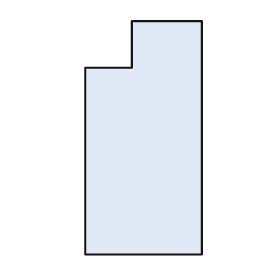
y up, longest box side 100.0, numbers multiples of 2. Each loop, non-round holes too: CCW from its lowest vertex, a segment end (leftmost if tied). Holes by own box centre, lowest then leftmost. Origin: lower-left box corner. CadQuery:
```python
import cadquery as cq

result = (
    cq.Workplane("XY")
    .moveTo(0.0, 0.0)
    .lineTo(50.0, 0.0)
    .lineTo(50.0, 100.0)
    .lineTo(20.0, 100.0)
    .lineTo(20.0, 80.0)
    .lineTo(0.0, 80.0)
    .close()
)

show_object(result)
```